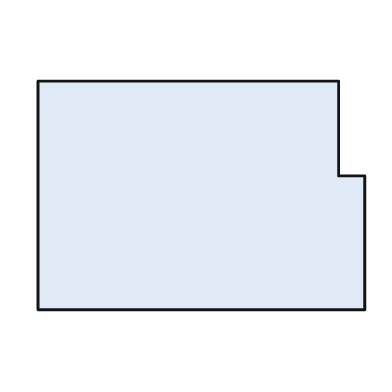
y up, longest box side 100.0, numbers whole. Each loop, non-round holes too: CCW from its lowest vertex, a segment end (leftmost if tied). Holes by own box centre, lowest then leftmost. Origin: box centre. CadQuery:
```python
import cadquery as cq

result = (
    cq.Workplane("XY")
    .moveTo(-50.0, -35.0)
    .lineTo(50.0, -35.0)
    .lineTo(50.0, 6.0)
    .lineTo(42.0, 6.0)
    .lineTo(42.0, 35.0)
    .lineTo(-50.0, 35.0)
    .close()
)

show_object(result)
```